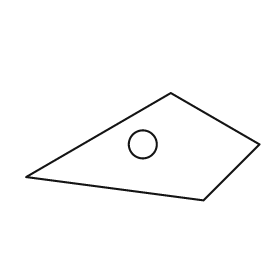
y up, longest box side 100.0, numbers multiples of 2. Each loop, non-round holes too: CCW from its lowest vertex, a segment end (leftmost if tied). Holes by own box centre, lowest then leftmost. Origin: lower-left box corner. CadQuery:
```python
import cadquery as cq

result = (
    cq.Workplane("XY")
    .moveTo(76.0, 0.0)
    .lineTo(100.0, 24.0)
    .lineTo(62.0, 46.0)
    .lineTo(0.0, 10.0)
    .close()
    .moveTo(50.0, 24.0)
    .circle(6.0)
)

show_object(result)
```